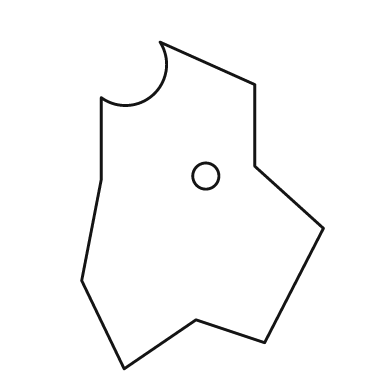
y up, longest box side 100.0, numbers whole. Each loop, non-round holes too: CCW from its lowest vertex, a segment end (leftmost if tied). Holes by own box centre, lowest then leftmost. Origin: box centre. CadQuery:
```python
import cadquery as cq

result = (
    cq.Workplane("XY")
    .moveTo(-24.0, -50.0)
    .lineTo(-2.0, -35.0)
    .lineTo(19.0, -42.0)
    .lineTo(37.0, -7.0)
    .lineTo(16.0, 12.0)
    .lineTo(16.0, 37.0)
    .lineTo(-13.0, 50.0)
    .threePointArc((-15.0, 34.0), (-31.0, 33.0))
    .lineTo(-31.0, 8.0)
    .lineTo(-37.0, -23.0)
    .close()
    .moveTo(1.0, 9.0)
    .circle(4.0)
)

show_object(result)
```